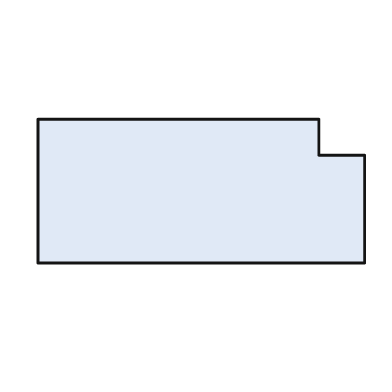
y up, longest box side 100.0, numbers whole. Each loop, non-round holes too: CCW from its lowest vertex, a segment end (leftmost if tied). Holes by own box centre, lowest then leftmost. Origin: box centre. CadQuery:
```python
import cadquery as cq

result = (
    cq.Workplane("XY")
    .moveTo(-50.0, -22.0)
    .lineTo(50.0, -22.0)
    .lineTo(50.0, 11.0)
    .lineTo(36.0, 11.0)
    .lineTo(36.0, 22.0)
    .lineTo(-50.0, 22.0)
    .close()
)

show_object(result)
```